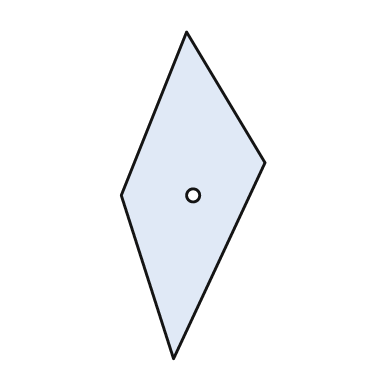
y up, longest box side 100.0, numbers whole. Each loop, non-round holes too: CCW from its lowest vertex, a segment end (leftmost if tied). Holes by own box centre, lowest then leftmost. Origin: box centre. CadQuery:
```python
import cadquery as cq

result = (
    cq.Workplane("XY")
    .moveTo(-6.0, -50.0)
    .lineTo(22.0, 10.0)
    .lineTo(-2.0, 50.0)
    .lineTo(-22.0, 0.0)
    .close()
    .moveTo(0.0, 0.0)
    .circle(2.0)
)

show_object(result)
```